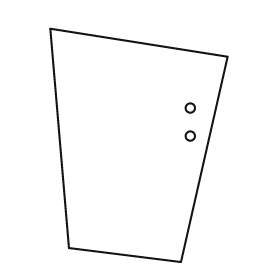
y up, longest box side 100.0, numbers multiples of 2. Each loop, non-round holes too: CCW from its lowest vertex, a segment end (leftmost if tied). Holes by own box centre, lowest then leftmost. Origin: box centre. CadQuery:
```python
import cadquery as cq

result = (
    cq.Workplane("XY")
    .moveTo(18.0, -50.0)
    .lineTo(38.0, 38.0)
    .lineTo(-38.0, 50.0)
    .lineTo(-30.0, -44.0)
    .close()
    .moveTo(22.0, 4.0)
    .circle(2.0)
    .moveTo(22.0, 16.0)
    .circle(2.0)
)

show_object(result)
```